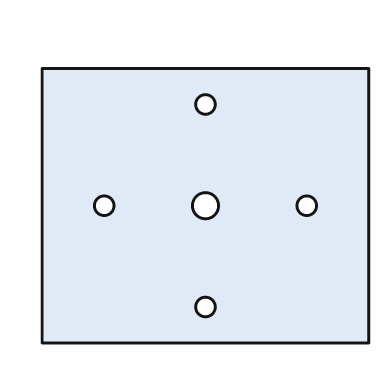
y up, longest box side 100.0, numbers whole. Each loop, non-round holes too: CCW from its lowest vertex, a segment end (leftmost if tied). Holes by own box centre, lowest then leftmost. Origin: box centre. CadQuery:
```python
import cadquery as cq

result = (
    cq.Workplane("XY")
    .moveTo(-50.0, -42.0)
    .lineTo(50.0, -42.0)
    .lineTo(50.0, 42.0)
    .lineTo(-50.0, 42.0)
    .close()
    .moveTo(0.0, -31.0)
    .circle(3.0)
    .moveTo(-31.0, 0.0)
    .circle(3.0)
    .moveTo(0.0, 0.0)
    .circle(4.0)
    .moveTo(31.0, 0.0)
    .circle(3.0)
    .moveTo(0.0, 31.0)
    .circle(3.0)
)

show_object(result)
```